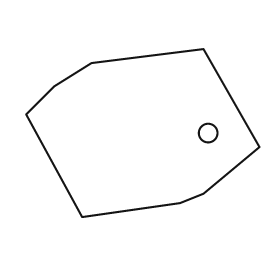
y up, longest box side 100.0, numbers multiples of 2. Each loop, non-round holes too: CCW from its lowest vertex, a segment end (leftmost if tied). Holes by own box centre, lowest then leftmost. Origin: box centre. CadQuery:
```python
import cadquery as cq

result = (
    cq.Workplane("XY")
    .moveTo(-26.0, -36.0)
    .lineTo(16.0, -30.0)
    .lineTo(26.0, -26.0)
    .lineTo(50.0, -6.0)
    .lineTo(26.0, 36.0)
    .lineTo(-22.0, 30.0)
    .lineTo(-38.0, 20.0)
    .lineTo(-50.0, 8.0)
    .close()
    .moveTo(28.0, 0.0)
    .circle(4.0)
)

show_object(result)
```